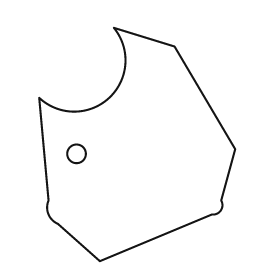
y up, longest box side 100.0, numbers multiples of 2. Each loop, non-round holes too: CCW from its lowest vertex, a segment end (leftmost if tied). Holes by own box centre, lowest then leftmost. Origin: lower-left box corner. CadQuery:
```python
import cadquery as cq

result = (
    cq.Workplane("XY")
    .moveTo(26.0, 0.0)
    .lineTo(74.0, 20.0)
    .threePointArc((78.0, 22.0), (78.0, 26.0))
    .lineTo(84.0, 48.0)
    .lineTo(58.0, 92.0)
    .lineTo(32.0, 100.0)
    .threePointArc((30.0, 70.0), (0.0, 70.0))
    .lineTo(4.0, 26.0)
    .threePointArc((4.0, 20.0), (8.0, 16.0))
    .close()
    .moveTo(16.0, 46.0)
    .circle(4.0)
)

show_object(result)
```